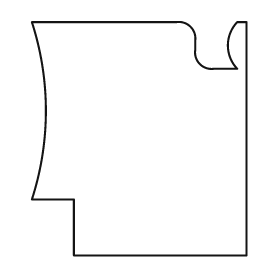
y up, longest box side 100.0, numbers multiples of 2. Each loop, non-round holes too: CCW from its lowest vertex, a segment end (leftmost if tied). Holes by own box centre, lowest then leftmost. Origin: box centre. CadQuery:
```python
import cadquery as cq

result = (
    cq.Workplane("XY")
    .moveTo(-28.0, -50.0)
    .lineTo(46.0, -50.0)
    .lineTo(46.0, 50.0)
    .lineTo(42.0, 50.0)
    .threePointArc((38.0, 40.0), (42.0, 30.0))
    .lineTo(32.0, 30.0)
    .threePointArc((26.0, 32.0), (24.0, 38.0))
    .lineTo(24.0, 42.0)
    .threePointArc((22.0, 48.0), (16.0, 50.0))
    .lineTo(-46.0, 50.0)
    .threePointArc((-40.0, 12.0), (-46.0, -26.0))
    .lineTo(-28.0, -26.0)
    .close()
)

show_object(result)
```